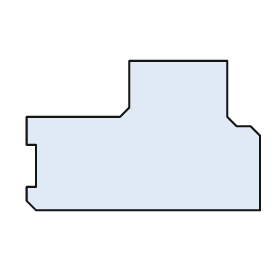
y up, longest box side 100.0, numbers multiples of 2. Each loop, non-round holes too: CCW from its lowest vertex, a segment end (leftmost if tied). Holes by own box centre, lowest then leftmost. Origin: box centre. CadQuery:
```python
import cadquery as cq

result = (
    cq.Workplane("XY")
    .moveTo(-46.0, -32.0)
    .lineTo(50.0, -32.0)
    .lineTo(50.0, 0.0)
    .lineTo(46.0, 4.0)
    .lineTo(40.0, 4.0)
    .lineTo(36.0, 8.0)
    .lineTo(36.0, 32.0)
    .lineTo(-6.0, 32.0)
    .lineTo(-6.0, 12.0)
    .lineTo(-10.0, 8.0)
    .lineTo(-50.0, 8.0)
    .lineTo(-50.0, -4.0)
    .lineTo(-46.0, -4.0)
    .lineTo(-46.0, -22.0)
    .lineTo(-50.0, -22.0)
    .lineTo(-50.0, -28.0)
    .close()
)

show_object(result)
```